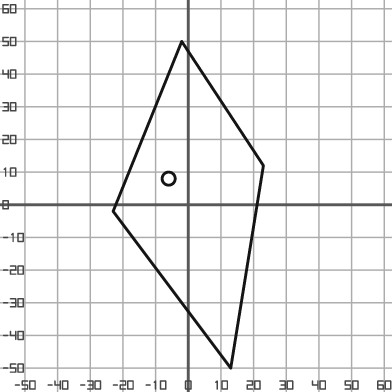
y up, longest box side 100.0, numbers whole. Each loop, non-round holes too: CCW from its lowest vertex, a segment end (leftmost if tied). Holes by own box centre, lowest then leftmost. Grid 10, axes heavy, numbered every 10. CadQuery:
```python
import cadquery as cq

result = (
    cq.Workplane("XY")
    .moveTo(13.0, -50.0)
    .lineTo(23.0, 12.0)
    .lineTo(-2.0, 50.0)
    .lineTo(-23.0, -2.0)
    .close()
    .moveTo(-6.0, 8.0)
    .circle(2.0)
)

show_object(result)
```